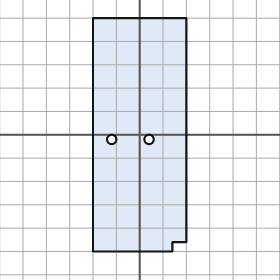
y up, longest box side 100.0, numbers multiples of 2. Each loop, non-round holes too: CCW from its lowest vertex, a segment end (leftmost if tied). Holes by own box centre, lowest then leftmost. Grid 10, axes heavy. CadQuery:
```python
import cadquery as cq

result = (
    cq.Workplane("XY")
    .moveTo(-20.0, -50.0)
    .lineTo(14.0, -50.0)
    .lineTo(14.0, -46.0)
    .lineTo(20.0, -46.0)
    .lineTo(20.0, 50.0)
    .lineTo(-20.0, 50.0)
    .close()
    .moveTo(-12.0, -2.0)
    .circle(2.0)
    .moveTo(4.0, -2.0)
    .circle(2.0)
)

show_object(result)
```